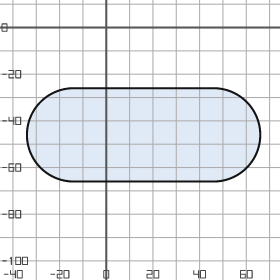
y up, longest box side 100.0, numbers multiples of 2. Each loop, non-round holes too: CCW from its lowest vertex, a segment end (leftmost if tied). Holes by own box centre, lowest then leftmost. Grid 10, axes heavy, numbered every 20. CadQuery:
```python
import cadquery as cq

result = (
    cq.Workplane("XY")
    .moveTo(-14.0, -66.0)
    .lineTo(46.0, -66.0)
    .threePointArc((66.0, -46.0), (46.0, -26.0))
    .lineTo(-14.0, -26.0)
    .threePointArc((-34.0, -46.0), (-14.0, -66.0))
    .close()
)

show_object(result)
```